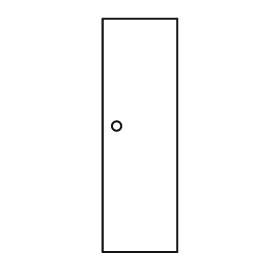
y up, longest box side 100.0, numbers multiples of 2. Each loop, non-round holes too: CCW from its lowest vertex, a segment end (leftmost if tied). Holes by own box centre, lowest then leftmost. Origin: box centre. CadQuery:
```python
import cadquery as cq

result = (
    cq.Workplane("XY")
    .moveTo(-16.0, -50.0)
    .lineTo(16.0, -50.0)
    .lineTo(16.0, 50.0)
    .lineTo(-16.0, 50.0)
    .close()
    .moveTo(-10.0, 4.0)
    .circle(2.0)
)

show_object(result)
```